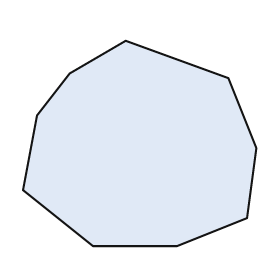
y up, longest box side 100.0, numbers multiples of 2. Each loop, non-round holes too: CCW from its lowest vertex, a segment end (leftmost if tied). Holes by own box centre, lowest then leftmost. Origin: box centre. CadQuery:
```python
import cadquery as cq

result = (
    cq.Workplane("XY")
    .moveTo(-20.0, -44.0)
    .lineTo(16.0, -44.0)
    .lineTo(46.0, -32.0)
    .lineTo(50.0, -2.0)
    .lineTo(38.0, 28.0)
    .lineTo(-6.0, 44.0)
    .lineTo(-30.0, 30.0)
    .lineTo(-44.0, 12.0)
    .lineTo(-50.0, -20.0)
    .close()
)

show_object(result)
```